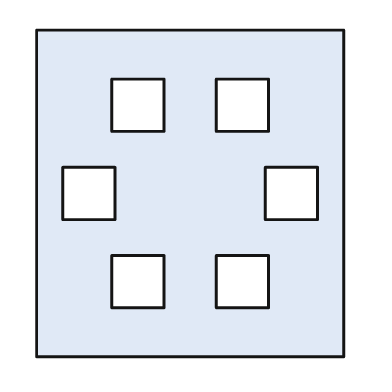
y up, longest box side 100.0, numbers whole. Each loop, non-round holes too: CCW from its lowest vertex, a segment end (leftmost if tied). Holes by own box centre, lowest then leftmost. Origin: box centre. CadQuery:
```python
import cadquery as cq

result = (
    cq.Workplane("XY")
    .moveTo(-47.0, -50.0)
    .lineTo(47.0, -50.0)
    .lineTo(47.0, 50.0)
    .lineTo(-47.0, 50.0)
    .close()
    .moveTo(-24.0, -35.0)
    .lineTo(-8.0, -35.0)
    .lineTo(-8.0, -19.0)
    .lineTo(-24.0, -19.0)
    .close()
    .moveTo(8.0, -35.0)
    .lineTo(24.0, -35.0)
    .lineTo(24.0, -19.0)
    .lineTo(8.0, -19.0)
    .close()
    .moveTo(-39.0, -8.0)
    .lineTo(-23.0, -8.0)
    .lineTo(-23.0, 8.0)
    .lineTo(-39.0, 8.0)
    .close()
    .moveTo(23.0, -8.0)
    .lineTo(39.0, -8.0)
    .lineTo(39.0, 8.0)
    .lineTo(23.0, 8.0)
    .close()
    .moveTo(-24.0, 19.0)
    .lineTo(-8.0, 19.0)
    .lineTo(-8.0, 35.0)
    .lineTo(-24.0, 35.0)
    .close()
    .moveTo(8.0, 19.0)
    .lineTo(24.0, 19.0)
    .lineTo(24.0, 35.0)
    .lineTo(8.0, 35.0)
    .close()
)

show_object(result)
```